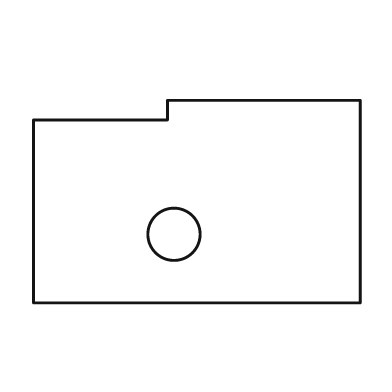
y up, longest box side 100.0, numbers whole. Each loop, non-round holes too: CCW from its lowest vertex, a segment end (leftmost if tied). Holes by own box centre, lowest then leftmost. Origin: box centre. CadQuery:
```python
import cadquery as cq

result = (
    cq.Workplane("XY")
    .moveTo(-50.0, -31.0)
    .lineTo(50.0, -31.0)
    .lineTo(50.0, 31.0)
    .lineTo(-9.0, 31.0)
    .lineTo(-9.0, 25.0)
    .lineTo(-50.0, 25.0)
    .close()
    .moveTo(-7.0, -10.0)
    .circle(8.0)
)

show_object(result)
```